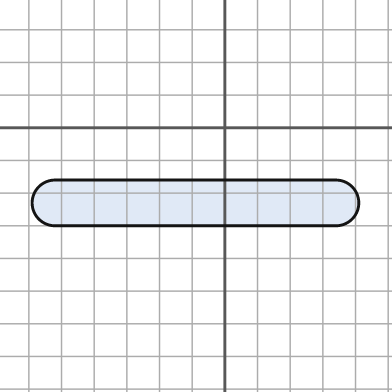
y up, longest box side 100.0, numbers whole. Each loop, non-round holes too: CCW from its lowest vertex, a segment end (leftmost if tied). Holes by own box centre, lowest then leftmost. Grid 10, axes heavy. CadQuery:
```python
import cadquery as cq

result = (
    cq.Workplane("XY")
    .moveTo(-52.0, -30.0)
    .lineTo(34.0, -30.0)
    .threePointArc((41.0, -23.0), (34.0, -16.0))
    .lineTo(-52.0, -16.0)
    .threePointArc((-59.0, -23.0), (-52.0, -30.0))
    .close()
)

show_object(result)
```